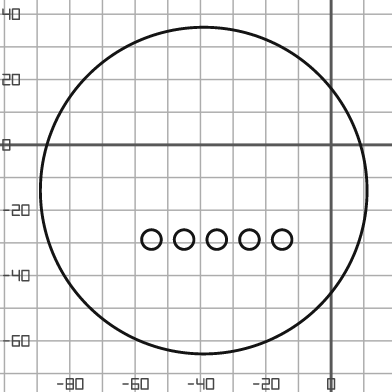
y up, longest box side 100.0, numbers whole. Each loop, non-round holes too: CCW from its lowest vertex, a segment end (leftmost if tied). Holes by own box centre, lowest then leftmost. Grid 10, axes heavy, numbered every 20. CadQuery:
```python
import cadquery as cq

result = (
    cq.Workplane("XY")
    .moveTo(-39.0, -14.0)
    .circle(50.0)
    .moveTo(-55.0, -29.0)
    .circle(3.0)
    .moveTo(-45.0, -29.0)
    .circle(3.0)
    .moveTo(-35.0, -29.0)
    .circle(3.0)
    .moveTo(-25.0, -29.0)
    .circle(3.0)
    .moveTo(-15.0, -29.0)
    .circle(3.0)
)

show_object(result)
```